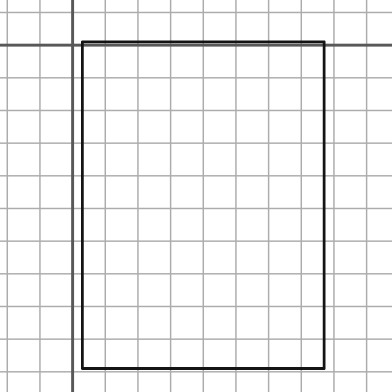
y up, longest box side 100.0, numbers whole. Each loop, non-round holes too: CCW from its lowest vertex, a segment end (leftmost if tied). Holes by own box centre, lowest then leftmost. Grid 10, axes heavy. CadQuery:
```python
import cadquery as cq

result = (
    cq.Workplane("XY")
    .moveTo(3.0, -99.0)
    .lineTo(77.0, -99.0)
    .lineTo(77.0, 1.0)
    .lineTo(3.0, 1.0)
    .close()
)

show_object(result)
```